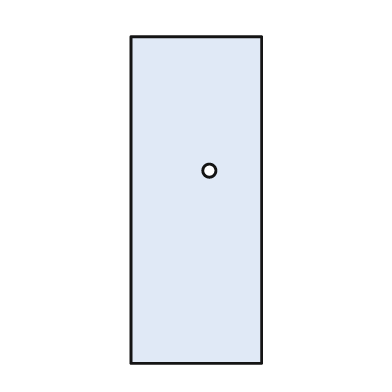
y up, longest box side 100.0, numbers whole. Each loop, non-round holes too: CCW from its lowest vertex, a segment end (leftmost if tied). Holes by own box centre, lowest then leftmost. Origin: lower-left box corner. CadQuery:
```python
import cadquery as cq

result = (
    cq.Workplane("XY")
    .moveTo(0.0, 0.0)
    .lineTo(40.0, 0.0)
    .lineTo(40.0, 100.0)
    .lineTo(0.0, 100.0)
    .close()
    .moveTo(24.0, 59.0)
    .circle(2.0)
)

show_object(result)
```